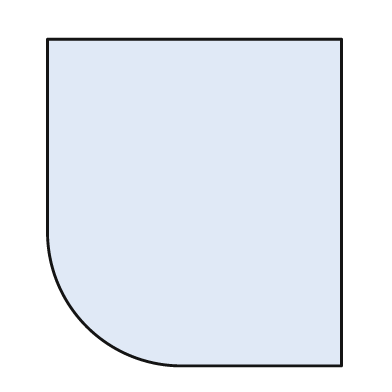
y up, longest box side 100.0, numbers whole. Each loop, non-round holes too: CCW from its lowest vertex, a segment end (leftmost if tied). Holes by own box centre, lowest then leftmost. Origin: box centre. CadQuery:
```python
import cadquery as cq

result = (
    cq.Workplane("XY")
    .moveTo(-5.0, -50.0)
    .lineTo(45.0, -50.0)
    .lineTo(45.0, 50.0)
    .lineTo(-45.0, 50.0)
    .lineTo(-45.0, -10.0)
    .threePointArc((-33.0, -38.0), (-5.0, -50.0))
    .close()
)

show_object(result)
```